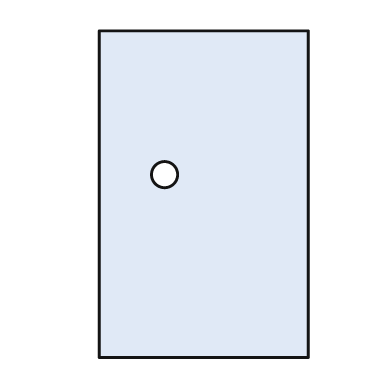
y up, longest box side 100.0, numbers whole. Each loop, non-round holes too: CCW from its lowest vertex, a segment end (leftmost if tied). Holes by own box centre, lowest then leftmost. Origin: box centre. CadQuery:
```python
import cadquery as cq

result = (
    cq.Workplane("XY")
    .moveTo(-32.0, -50.0)
    .lineTo(32.0, -50.0)
    .lineTo(32.0, 50.0)
    .lineTo(-32.0, 50.0)
    .close()
    .moveTo(-12.0, 6.0)
    .circle(4.0)
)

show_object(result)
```